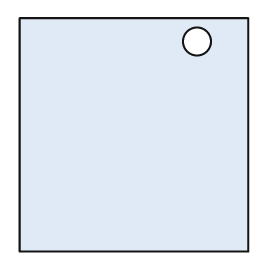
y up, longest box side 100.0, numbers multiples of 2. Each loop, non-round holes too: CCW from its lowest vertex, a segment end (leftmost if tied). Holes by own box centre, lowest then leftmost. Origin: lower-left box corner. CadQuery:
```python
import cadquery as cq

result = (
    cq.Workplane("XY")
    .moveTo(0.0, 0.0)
    .lineTo(98.0, 0.0)
    .lineTo(98.0, 100.0)
    .lineTo(0.0, 100.0)
    .close()
    .moveTo(76.0, 90.0)
    .circle(6.0)
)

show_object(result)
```